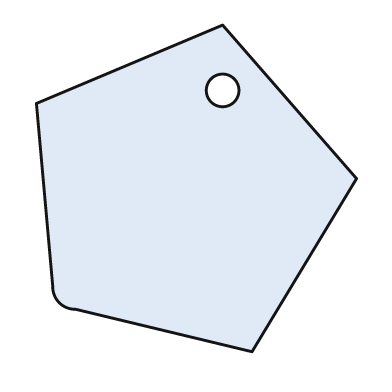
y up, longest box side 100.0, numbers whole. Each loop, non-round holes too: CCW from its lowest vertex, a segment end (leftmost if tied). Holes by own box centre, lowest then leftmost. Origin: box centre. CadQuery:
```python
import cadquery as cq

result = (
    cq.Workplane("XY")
    .moveTo(17.0, -50.0)
    .lineTo(49.0, 3.0)
    .lineTo(8.0, 50.0)
    .lineTo(-49.0, 26.0)
    .lineTo(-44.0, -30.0)
    .threePointArc((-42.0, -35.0), (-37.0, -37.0))
    .close()
    .moveTo(8.0, 30.0)
    .circle(5.0)
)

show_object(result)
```